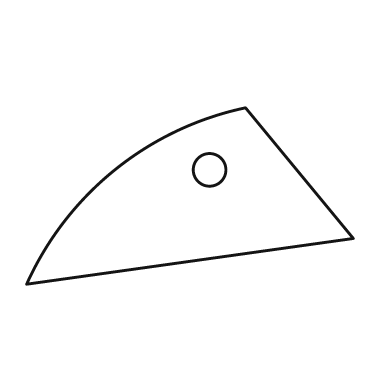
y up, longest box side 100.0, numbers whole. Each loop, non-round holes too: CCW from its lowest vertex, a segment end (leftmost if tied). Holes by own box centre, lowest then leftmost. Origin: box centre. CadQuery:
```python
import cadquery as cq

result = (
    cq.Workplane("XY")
    .moveTo(-50.0, -27.0)
    .lineTo(50.0, -13.0)
    .lineTo(17.0, 27.0)
    .threePointArc((-23.0, 8.0), (-50.0, -27.0))
    .close()
    .moveTo(6.0, 8.0)
    .circle(5.0)
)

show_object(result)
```